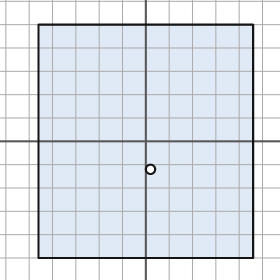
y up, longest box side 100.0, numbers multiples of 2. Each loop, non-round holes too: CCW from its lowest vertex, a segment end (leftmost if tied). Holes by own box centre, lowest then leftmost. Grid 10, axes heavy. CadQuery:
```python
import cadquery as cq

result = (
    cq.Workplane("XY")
    .moveTo(-46.0, -50.0)
    .lineTo(46.0, -50.0)
    .lineTo(46.0, 50.0)
    .lineTo(-46.0, 50.0)
    .close()
    .moveTo(2.0, -12.0)
    .circle(2.0)
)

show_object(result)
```